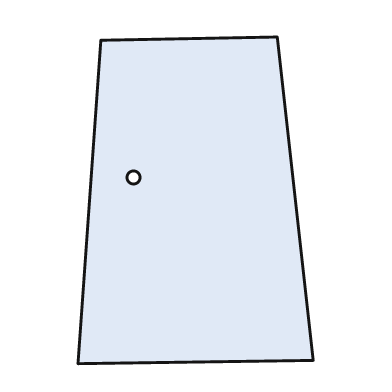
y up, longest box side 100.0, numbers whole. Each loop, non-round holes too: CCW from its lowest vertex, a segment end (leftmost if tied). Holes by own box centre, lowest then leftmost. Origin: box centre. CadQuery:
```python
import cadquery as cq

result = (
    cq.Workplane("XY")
    .moveTo(-36.0, -50.0)
    .lineTo(36.0, -49.0)
    .lineTo(25.0, 50.0)
    .lineTo(-29.0, 49.0)
    .close()
    .moveTo(-19.0, 7.0)
    .circle(2.0)
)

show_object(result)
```